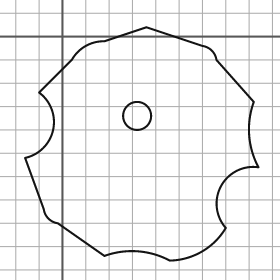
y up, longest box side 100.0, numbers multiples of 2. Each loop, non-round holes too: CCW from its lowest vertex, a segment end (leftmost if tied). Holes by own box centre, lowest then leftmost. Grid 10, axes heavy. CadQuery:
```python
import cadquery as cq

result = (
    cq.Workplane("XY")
    .moveTo(46.0, -96.0)
    .threePointArc((60.0, -92.0), (70.0, -82.0))
    .threePointArc((68.0, -64.0), (84.0, -56.0))
    .threePointArc((80.0, -42.0), (82.0, -28.0))
    .lineTo(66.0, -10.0)
    .threePointArc((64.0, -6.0), (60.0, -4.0))
    .lineTo(36.0, 4.0)
    .lineTo(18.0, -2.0)
    .threePointArc((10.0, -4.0), (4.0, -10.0))
    .lineTo(-10.0, -24.0)
    .threePointArc((-4.0, -40.0), (-16.0, -52.0))
    .lineTo(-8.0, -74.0)
    .threePointArc((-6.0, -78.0), (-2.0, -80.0))
    .lineTo(18.0, -94.0)
    .threePointArc((32.0, -92.0), (46.0, -96.0))
    .close()
    .moveTo(32.0, -34.0)
    .circle(6.0)
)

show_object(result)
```